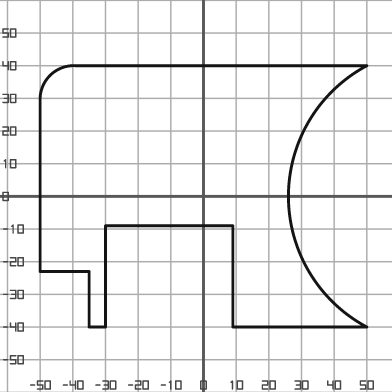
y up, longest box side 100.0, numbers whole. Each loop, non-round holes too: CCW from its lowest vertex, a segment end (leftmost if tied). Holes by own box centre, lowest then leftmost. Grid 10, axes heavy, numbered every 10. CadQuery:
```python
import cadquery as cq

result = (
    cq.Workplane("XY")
    .moveTo(-35.0, -40.0)
    .lineTo(-30.0, -40.0)
    .lineTo(-30.0, -9.0)
    .lineTo(9.0, -9.0)
    .lineTo(9.0, -40.0)
    .lineTo(50.0, -40.0)
    .threePointArc((26.0, 0.0), (50.0, 40.0))
    .lineTo(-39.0, 40.0)
    .threePointArc((-47.0, 37.0), (-50.0, 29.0))
    .lineTo(-50.0, -23.0)
    .lineTo(-35.0, -23.0)
    .close()
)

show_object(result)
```